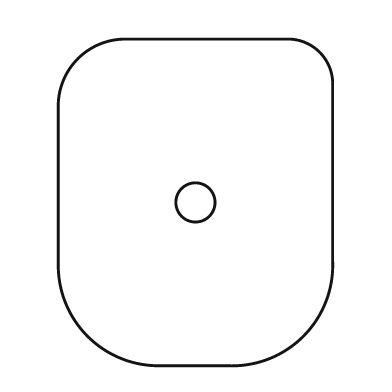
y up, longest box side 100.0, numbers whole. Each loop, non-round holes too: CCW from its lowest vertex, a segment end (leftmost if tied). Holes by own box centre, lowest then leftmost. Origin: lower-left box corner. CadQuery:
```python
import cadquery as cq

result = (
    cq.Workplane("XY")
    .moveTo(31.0, 0.0)
    .lineTo(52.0, 0.0)
    .threePointArc((75.0, 9.0), (84.0, 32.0))
    .lineTo(84.0, 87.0)
    .threePointArc((80.0, 96.0), (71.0, 100.0))
    .lineTo(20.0, 100.0)
    .threePointArc((6.0, 94.0), (0.0, 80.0))
    .lineTo(0.0, 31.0)
    .threePointArc((9.0, 9.0), (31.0, 0.0))
    .close()
    .moveTo(42.0, 50.0)
    .circle(6.0)
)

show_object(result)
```